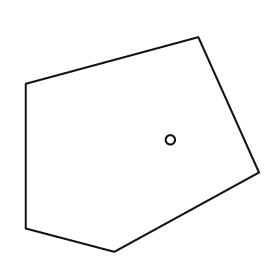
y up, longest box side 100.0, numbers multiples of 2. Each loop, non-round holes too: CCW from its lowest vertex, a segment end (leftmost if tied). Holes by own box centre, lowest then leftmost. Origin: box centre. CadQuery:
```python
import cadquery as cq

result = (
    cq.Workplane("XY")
    .moveTo(-12.0, -46.0)
    .lineTo(50.0, -12.0)
    .lineTo(24.0, 46.0)
    .lineTo(-50.0, 26.0)
    .lineTo(-50.0, -36.0)
    .close()
    .moveTo(12.0, 2.0)
    .circle(2.0)
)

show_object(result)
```